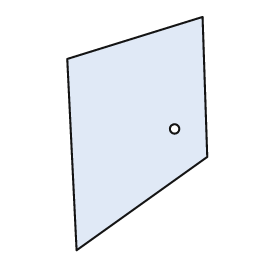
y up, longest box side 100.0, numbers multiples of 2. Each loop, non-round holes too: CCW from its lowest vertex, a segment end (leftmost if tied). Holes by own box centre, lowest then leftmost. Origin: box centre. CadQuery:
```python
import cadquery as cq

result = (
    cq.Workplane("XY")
    .moveTo(-26.0, -50.0)
    .lineTo(30.0, -10.0)
    .lineTo(28.0, 50.0)
    .lineTo(-30.0, 32.0)
    .close()
    .moveTo(16.0, 2.0)
    .circle(2.0)
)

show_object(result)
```